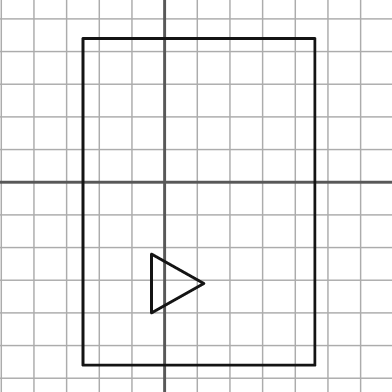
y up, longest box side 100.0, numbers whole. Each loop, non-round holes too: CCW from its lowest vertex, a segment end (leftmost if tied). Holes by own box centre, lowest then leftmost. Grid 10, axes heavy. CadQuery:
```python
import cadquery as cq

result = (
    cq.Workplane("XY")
    .moveTo(-25.0, -56.0)
    .lineTo(46.0, -56.0)
    .lineTo(46.0, 44.0)
    .lineTo(-25.0, 44.0)
    .close()
    .moveTo(-4.0, -40.0)
    .lineTo(12.0, -31.0)
    .lineTo(-4.0, -22.0)
    .close()
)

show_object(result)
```